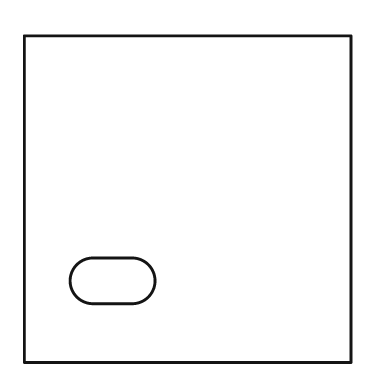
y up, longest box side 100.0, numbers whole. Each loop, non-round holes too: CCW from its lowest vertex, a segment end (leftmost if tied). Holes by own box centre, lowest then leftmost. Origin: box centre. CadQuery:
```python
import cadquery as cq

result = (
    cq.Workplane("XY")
    .moveTo(-50.0, -50.0)
    .lineTo(50.0, -50.0)
    .lineTo(50.0, 50.0)
    .lineTo(-50.0, 50.0)
    .close()
    .moveTo(-29.0, -32.0)
    .lineTo(-17.0, -32.0)
    .threePointArc((-10.0, -25.0), (-17.0, -18.0))
    .lineTo(-29.0, -18.0)
    .threePointArc((-36.0, -25.0), (-29.0, -32.0))
    .close()
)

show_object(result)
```